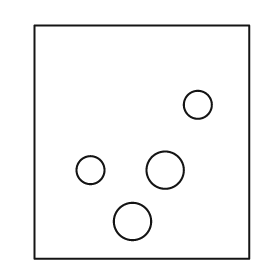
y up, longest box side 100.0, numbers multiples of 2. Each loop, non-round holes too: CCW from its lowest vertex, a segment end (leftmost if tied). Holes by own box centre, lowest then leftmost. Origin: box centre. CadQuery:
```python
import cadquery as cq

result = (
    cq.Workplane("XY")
    .moveTo(-46.0, -50.0)
    .lineTo(46.0, -50.0)
    .lineTo(46.0, 50.0)
    .lineTo(-46.0, 50.0)
    .close()
    .moveTo(-4.0, -34.0)
    .circle(8.0)
    .moveTo(-22.0, -12.0)
    .circle(6.0)
    .moveTo(10.0, -12.0)
    .circle(8.0)
    .moveTo(24.0, 16.0)
    .circle(6.0)
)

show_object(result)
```